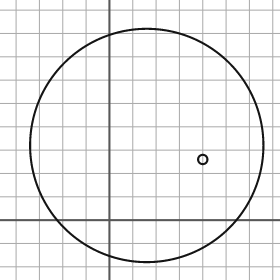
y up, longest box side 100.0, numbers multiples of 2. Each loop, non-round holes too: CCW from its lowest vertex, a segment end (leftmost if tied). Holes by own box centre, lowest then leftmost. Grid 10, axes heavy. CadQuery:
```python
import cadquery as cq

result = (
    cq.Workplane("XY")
    .moveTo(16.0, 32.0)
    .circle(50.0)
    .moveTo(40.0, 26.0)
    .circle(2.0)
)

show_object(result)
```